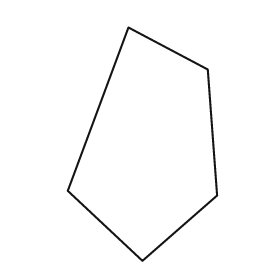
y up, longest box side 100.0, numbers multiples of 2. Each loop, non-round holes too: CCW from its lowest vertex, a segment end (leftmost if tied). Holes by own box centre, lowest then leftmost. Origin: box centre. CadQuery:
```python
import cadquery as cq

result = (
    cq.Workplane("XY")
    .moveTo(0.0, -50.0)
    .lineTo(32.0, -22.0)
    .lineTo(28.0, 32.0)
    .lineTo(-6.0, 50.0)
    .lineTo(-32.0, -20.0)
    .close()
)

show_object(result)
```